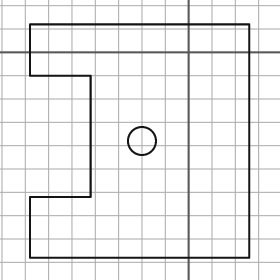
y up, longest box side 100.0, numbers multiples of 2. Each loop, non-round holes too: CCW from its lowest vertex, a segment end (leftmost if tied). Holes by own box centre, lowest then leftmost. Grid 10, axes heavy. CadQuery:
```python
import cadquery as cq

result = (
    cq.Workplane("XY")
    .moveTo(-68.0, -88.0)
    .lineTo(26.0, -88.0)
    .lineTo(26.0, 12.0)
    .lineTo(-68.0, 12.0)
    .lineTo(-68.0, -10.0)
    .lineTo(-42.0, -10.0)
    .lineTo(-42.0, -62.0)
    .lineTo(-68.0, -62.0)
    .close()
    .moveTo(-20.0, -38.0)
    .circle(6.0)
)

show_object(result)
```